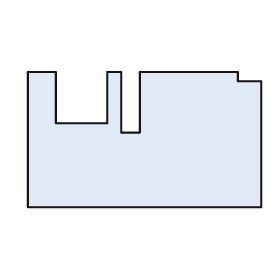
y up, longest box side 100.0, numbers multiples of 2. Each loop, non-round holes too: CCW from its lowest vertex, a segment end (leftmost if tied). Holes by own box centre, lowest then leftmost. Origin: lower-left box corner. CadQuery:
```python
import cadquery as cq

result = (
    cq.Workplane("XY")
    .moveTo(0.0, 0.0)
    .lineTo(100.0, 0.0)
    .lineTo(100.0, 54.0)
    .lineTo(90.0, 54.0)
    .lineTo(90.0, 58.0)
    .lineTo(48.0, 58.0)
    .lineTo(48.0, 32.0)
    .lineTo(40.0, 32.0)
    .lineTo(40.0, 58.0)
    .lineTo(34.0, 58.0)
    .lineTo(34.0, 36.0)
    .lineTo(12.0, 36.0)
    .lineTo(12.0, 58.0)
    .lineTo(0.0, 58.0)
    .close()
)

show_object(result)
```